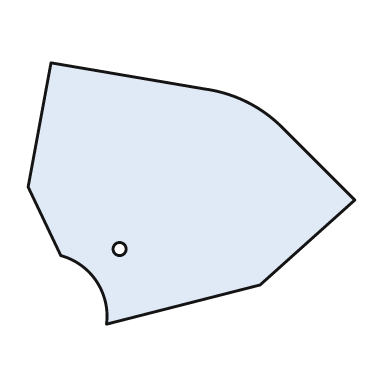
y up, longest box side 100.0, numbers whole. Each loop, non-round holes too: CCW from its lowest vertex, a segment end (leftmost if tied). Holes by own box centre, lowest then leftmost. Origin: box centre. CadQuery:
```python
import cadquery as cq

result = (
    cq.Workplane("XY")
    .moveTo(-26.0, -40.0)
    .lineTo(21.0, -28.0)
    .lineTo(50.0, -2.0)
    .lineTo(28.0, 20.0)
    .threePointArc((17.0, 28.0), (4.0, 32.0))
    .lineTo(-43.0, 40.0)
    .lineTo(-50.0, 2.0)
    .lineTo(-40.0, -19.0)
    .threePointArc((-29.0, -27.0), (-26.0, -40.0))
    .close()
    .moveTo(-22.0, -17.0)
    .circle(2.0)
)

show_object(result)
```